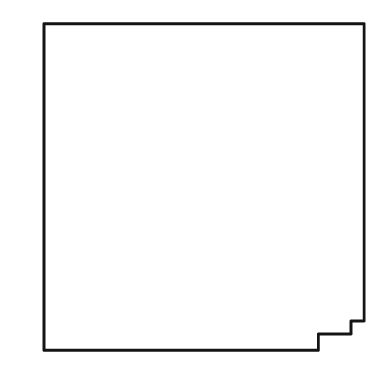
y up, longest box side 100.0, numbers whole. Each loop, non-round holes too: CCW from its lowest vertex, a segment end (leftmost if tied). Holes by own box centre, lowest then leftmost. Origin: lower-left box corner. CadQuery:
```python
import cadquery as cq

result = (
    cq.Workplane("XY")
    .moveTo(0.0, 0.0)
    .lineTo(84.0, 0.0)
    .lineTo(84.0, 5.0)
    .lineTo(94.0, 5.0)
    .lineTo(94.0, 9.0)
    .lineTo(98.0, 9.0)
    .lineTo(98.0, 100.0)
    .lineTo(0.0, 100.0)
    .close()
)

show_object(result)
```